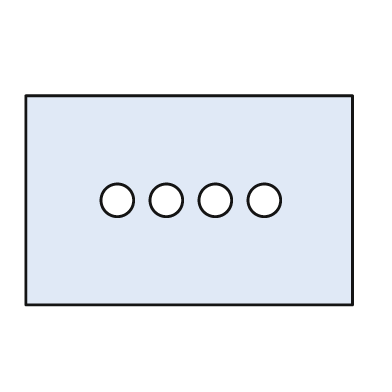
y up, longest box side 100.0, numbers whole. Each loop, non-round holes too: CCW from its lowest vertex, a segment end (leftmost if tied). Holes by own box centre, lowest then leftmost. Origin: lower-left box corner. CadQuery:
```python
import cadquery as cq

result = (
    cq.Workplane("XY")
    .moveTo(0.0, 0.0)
    .lineTo(100.0, 0.0)
    .lineTo(100.0, 64.0)
    .lineTo(0.0, 64.0)
    .close()
    .moveTo(28.0, 32.0)
    .circle(5.0)
    .moveTo(43.0, 32.0)
    .circle(5.0)
    .moveTo(58.0, 32.0)
    .circle(5.0)
    .moveTo(73.0, 32.0)
    .circle(5.0)
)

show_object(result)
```